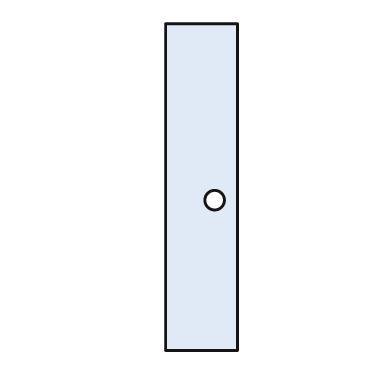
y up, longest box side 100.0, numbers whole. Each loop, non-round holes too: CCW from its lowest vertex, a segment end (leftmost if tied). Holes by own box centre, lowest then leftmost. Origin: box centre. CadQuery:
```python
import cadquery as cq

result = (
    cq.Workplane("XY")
    .moveTo(-11.0, -50.0)
    .lineTo(11.0, -50.0)
    .lineTo(11.0, 50.0)
    .lineTo(-11.0, 50.0)
    .close()
    .moveTo(4.0, -4.0)
    .circle(3.0)
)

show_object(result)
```